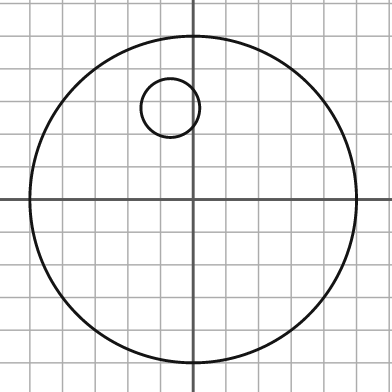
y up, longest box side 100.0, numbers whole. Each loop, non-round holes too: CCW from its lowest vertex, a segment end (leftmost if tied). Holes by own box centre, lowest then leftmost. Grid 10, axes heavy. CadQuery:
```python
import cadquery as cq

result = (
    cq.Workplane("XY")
    .moveTo(0.0, 0.0)
    .circle(50.0)
    .moveTo(-7.0, 28.0)
    .circle(9.0)
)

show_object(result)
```